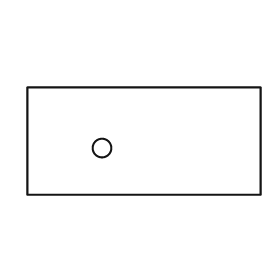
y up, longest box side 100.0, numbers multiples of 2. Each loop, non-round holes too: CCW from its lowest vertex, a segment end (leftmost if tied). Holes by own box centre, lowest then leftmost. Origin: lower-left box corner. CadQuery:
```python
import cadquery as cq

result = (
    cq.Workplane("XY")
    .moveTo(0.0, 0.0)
    .lineTo(100.0, 0.0)
    .lineTo(100.0, 46.0)
    .lineTo(0.0, 46.0)
    .close()
    .moveTo(32.0, 20.0)
    .circle(4.0)
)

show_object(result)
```